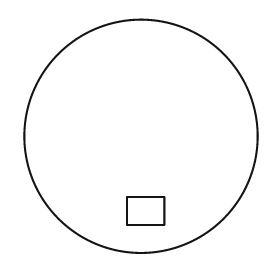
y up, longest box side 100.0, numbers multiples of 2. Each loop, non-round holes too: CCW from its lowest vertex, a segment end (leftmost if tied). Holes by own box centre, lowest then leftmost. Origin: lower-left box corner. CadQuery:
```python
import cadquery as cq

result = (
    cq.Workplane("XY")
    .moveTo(50.0, 50.0)
    .circle(50.0)
    .moveTo(44.0, 12.0)
    .lineTo(60.0, 12.0)
    .lineTo(60.0, 24.0)
    .lineTo(44.0, 24.0)
    .close()
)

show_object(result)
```